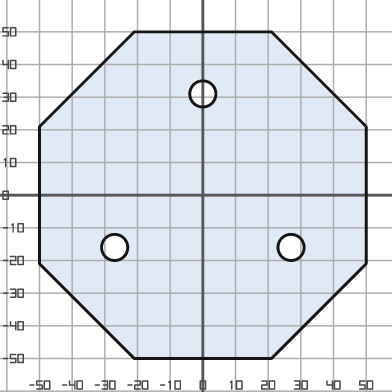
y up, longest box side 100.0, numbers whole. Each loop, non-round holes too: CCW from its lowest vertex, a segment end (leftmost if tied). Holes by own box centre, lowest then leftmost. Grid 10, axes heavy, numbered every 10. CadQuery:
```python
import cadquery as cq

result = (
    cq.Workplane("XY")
    .moveTo(-21.0, -50.0)
    .lineTo(21.0, -50.0)
    .lineTo(50.0, -21.0)
    .lineTo(50.0, 21.0)
    .lineTo(21.0, 50.0)
    .lineTo(-21.0, 50.0)
    .lineTo(-50.0, 21.0)
    .lineTo(-50.0, -21.0)
    .close()
    .moveTo(-27.0, -16.0)
    .circle(4.0)
    .moveTo(27.0, -16.0)
    .circle(4.0)
    .moveTo(0.0, 31.0)
    .circle(4.0)
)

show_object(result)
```